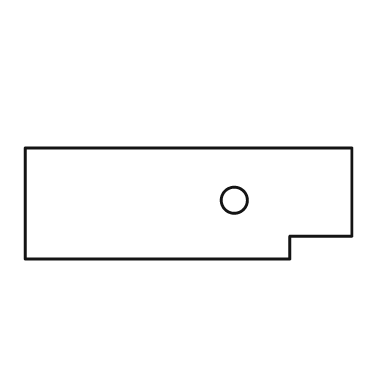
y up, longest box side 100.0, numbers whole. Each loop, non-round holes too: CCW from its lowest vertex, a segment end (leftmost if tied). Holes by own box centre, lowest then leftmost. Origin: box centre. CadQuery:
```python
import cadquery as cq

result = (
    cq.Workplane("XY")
    .moveTo(-50.0, -17.0)
    .lineTo(31.0, -17.0)
    .lineTo(31.0, -10.0)
    .lineTo(50.0, -10.0)
    .lineTo(50.0, 17.0)
    .lineTo(-50.0, 17.0)
    .close()
    .moveTo(14.0, 1.0)
    .circle(4.0)
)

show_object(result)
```